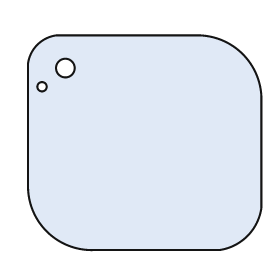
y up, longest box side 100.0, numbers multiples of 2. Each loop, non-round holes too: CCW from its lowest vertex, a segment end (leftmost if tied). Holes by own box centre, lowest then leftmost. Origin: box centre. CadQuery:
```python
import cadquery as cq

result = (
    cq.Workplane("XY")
    .moveTo(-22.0, -46.0)
    .lineTo(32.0, -46.0)
    .threePointArc((44.0, -40.0), (50.0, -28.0))
    .lineTo(50.0, 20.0)
    .threePointArc((42.0, 38.0), (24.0, 46.0))
    .lineTo(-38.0, 46.0)
    .threePointArc((-46.0, 42.0), (-50.0, 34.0))
    .lineTo(-50.0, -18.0)
    .threePointArc((-42.0, -38.0), (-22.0, -46.0))
    .close()
    .moveTo(-44.0, 24.0)
    .circle(2.0)
    .moveTo(-34.0, 32.0)
    .circle(4.0)
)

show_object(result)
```